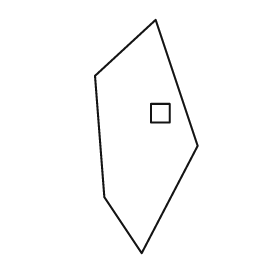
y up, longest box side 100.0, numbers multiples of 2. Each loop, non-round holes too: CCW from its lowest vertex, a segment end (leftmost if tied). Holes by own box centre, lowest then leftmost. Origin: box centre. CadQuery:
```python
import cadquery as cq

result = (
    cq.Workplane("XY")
    .moveTo(-2.0, -50.0)
    .lineTo(22.0, -4.0)
    .lineTo(4.0, 50.0)
    .lineTo(-22.0, 26.0)
    .lineTo(-18.0, -26.0)
    .close()
    .moveTo(2.0, 6.0)
    .lineTo(10.0, 6.0)
    .lineTo(10.0, 14.0)
    .lineTo(2.0, 14.0)
    .close()
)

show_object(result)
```